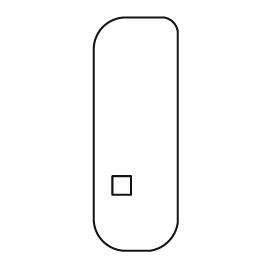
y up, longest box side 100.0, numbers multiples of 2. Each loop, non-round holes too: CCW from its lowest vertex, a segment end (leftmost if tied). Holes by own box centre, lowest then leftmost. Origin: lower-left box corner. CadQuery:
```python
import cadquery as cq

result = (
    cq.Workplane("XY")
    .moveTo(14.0, 0.0)
    .lineTo(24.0, 0.0)
    .threePointArc((32.0, 4.0), (36.0, 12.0))
    .lineTo(36.0, 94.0)
    .threePointArc((34.0, 98.0), (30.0, 100.0))
    .lineTo(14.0, 100.0)
    .threePointArc((4.0, 96.0), (0.0, 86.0))
    .lineTo(0.0, 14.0)
    .threePointArc((4.0, 4.0), (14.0, 0.0))
    .close()
    .moveTo(8.0, 24.0)
    .lineTo(16.0, 24.0)
    .lineTo(16.0, 32.0)
    .lineTo(8.0, 32.0)
    .close()
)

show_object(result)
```